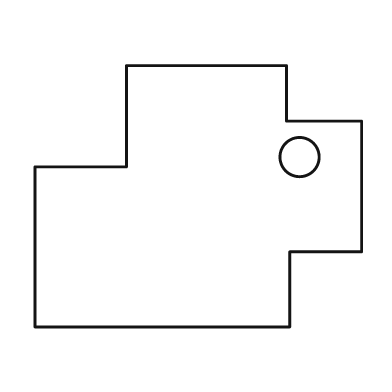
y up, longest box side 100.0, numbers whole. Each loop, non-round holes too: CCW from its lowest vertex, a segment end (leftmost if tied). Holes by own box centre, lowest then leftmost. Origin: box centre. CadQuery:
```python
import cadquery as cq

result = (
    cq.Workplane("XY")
    .moveTo(-50.0, -40.0)
    .lineTo(28.0, -40.0)
    .lineTo(28.0, -17.0)
    .lineTo(50.0, -17.0)
    .lineTo(50.0, 23.0)
    .lineTo(27.0, 23.0)
    .lineTo(27.0, 40.0)
    .lineTo(-22.0, 40.0)
    .lineTo(-22.0, 9.0)
    .lineTo(-50.0, 9.0)
    .close()
    .moveTo(31.0, 12.0)
    .circle(6.0)
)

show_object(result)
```